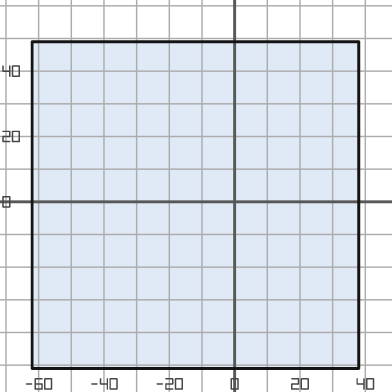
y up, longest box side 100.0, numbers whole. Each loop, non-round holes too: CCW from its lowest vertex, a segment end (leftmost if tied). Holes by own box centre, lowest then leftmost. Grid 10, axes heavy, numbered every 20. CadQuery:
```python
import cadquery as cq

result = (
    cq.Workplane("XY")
    .moveTo(-62.0, -51.0)
    .lineTo(38.0, -51.0)
    .lineTo(38.0, 49.0)
    .lineTo(-62.0, 49.0)
    .close()
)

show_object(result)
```